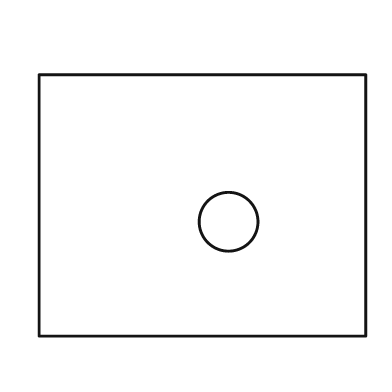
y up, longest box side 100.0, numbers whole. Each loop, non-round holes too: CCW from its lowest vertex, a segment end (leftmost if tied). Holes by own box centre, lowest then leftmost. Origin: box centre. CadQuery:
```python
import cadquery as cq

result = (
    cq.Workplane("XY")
    .moveTo(-50.0, -40.0)
    .lineTo(50.0, -40.0)
    .lineTo(50.0, 40.0)
    .lineTo(-50.0, 40.0)
    .close()
    .moveTo(8.0, -5.0)
    .circle(9.0)
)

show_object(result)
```